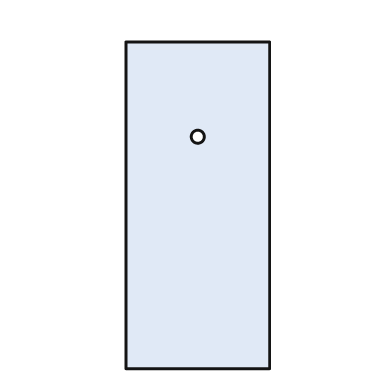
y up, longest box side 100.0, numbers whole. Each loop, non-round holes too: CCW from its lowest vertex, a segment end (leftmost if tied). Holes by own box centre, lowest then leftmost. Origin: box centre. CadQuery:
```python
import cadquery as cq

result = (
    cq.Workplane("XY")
    .moveTo(-22.0, -50.0)
    .lineTo(22.0, -50.0)
    .lineTo(22.0, 50.0)
    .lineTo(-22.0, 50.0)
    .close()
    .moveTo(0.0, 21.0)
    .circle(2.0)
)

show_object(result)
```